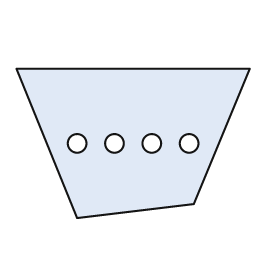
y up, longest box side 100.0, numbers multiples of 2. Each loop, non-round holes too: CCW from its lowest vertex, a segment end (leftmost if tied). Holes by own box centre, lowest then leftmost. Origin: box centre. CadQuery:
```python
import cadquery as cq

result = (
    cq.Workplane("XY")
    .moveTo(-24.0, -32.0)
    .lineTo(26.0, -26.0)
    .lineTo(50.0, 32.0)
    .lineTo(-50.0, 32.0)
    .close()
    .moveTo(-24.0, 0.0)
    .circle(4.0)
    .moveTo(-8.0, 0.0)
    .circle(4.0)
    .moveTo(8.0, 0.0)
    .circle(4.0)
    .moveTo(24.0, 0.0)
    .circle(4.0)
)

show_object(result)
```